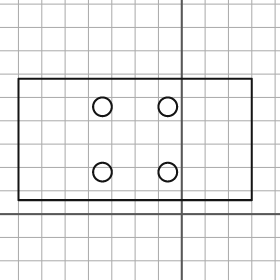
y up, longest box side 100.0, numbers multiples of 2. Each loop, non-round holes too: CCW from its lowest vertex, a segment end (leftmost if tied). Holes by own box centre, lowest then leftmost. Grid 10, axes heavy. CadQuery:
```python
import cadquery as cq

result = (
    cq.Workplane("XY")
    .moveTo(-70.0, 6.0)
    .lineTo(30.0, 6.0)
    .lineTo(30.0, 58.0)
    .lineTo(-70.0, 58.0)
    .close()
    .moveTo(-34.0, 18.0)
    .circle(4.0)
    .moveTo(-6.0, 18.0)
    .circle(4.0)
    .moveTo(-34.0, 46.0)
    .circle(4.0)
    .moveTo(-6.0, 46.0)
    .circle(4.0)
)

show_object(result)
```